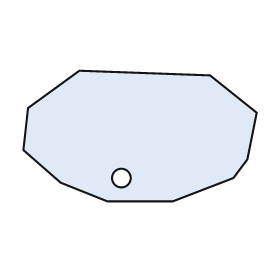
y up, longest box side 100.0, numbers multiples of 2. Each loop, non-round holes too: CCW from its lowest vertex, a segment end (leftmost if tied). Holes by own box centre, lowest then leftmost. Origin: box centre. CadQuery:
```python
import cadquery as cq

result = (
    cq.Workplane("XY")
    .moveTo(-14.0, -28.0)
    .lineTo(14.0, -28.0)
    .lineTo(40.0, -18.0)
    .lineTo(46.0, -10.0)
    .lineTo(50.0, 10.0)
    .lineTo(30.0, 26.0)
    .lineTo(-26.0, 28.0)
    .lineTo(-48.0, 12.0)
    .lineTo(-50.0, -6.0)
    .lineTo(-34.0, -20.0)
    .close()
    .moveTo(-8.0, -18.0)
    .circle(4.0)
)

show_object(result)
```